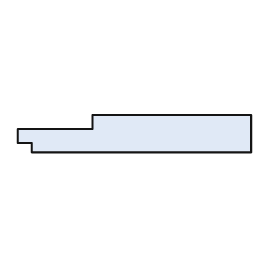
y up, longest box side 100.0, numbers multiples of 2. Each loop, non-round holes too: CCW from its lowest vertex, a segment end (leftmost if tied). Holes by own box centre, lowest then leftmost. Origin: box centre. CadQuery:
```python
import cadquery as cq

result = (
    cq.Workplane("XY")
    .moveTo(-44.0, -8.0)
    .lineTo(50.0, -8.0)
    .lineTo(50.0, 8.0)
    .lineTo(-18.0, 8.0)
    .lineTo(-18.0, 2.0)
    .lineTo(-50.0, 2.0)
    .lineTo(-50.0, -4.0)
    .lineTo(-44.0, -4.0)
    .close()
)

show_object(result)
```